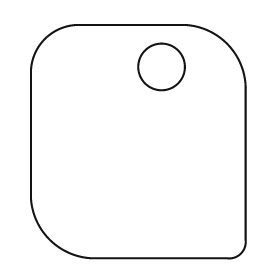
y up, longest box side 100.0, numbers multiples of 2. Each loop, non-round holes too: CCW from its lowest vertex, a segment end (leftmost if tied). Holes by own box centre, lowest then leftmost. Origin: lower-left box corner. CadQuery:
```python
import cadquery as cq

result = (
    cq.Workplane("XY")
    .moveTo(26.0, 0.0)
    .lineTo(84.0, 0.0)
    .threePointArc((90.0, 2.0), (92.0, 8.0))
    .lineTo(92.0, 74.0)
    .threePointArc((84.0, 92.0), (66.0, 100.0))
    .lineTo(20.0, 100.0)
    .threePointArc((6.0, 94.0), (0.0, 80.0))
    .lineTo(0.0, 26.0)
    .threePointArc((8.0, 8.0), (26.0, 0.0))
    .close()
    .moveTo(56.0, 82.0)
    .circle(10.0)
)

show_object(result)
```